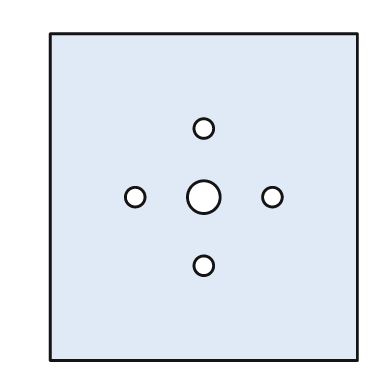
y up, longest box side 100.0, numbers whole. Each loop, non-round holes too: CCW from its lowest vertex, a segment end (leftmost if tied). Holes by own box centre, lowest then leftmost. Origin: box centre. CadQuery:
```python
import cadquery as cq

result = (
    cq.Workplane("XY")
    .moveTo(-47.0, -50.0)
    .lineTo(47.0, -50.0)
    .lineTo(47.0, 50.0)
    .lineTo(-47.0, 50.0)
    .close()
    .moveTo(0.0, -21.0)
    .circle(3.0)
    .moveTo(-21.0, 0.0)
    .circle(3.0)
    .moveTo(0.0, 0.0)
    .circle(5.0)
    .moveTo(21.0, 0.0)
    .circle(3.0)
    .moveTo(0.0, 21.0)
    .circle(3.0)
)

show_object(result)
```